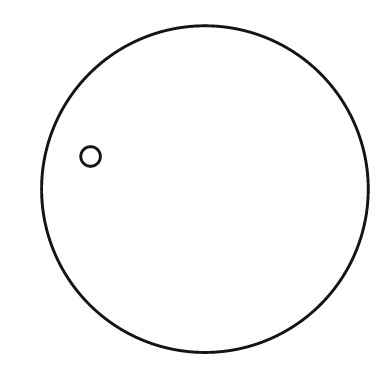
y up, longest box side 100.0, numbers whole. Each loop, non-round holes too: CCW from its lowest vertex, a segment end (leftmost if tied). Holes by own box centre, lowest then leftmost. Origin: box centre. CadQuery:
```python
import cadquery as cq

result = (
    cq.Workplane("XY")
    .moveTo(0.0, 0.0)
    .circle(50.0)
    .moveTo(-35.0, 10.0)
    .circle(3.0)
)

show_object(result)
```